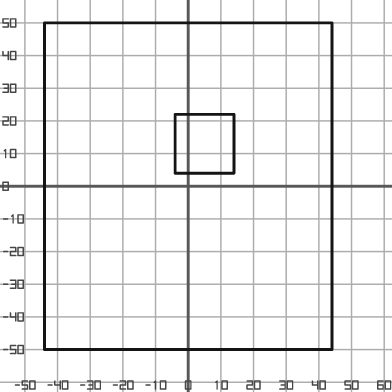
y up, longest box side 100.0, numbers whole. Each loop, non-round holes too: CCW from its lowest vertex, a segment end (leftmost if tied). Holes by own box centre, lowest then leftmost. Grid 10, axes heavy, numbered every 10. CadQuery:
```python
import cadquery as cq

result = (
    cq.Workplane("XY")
    .moveTo(-44.0, -50.0)
    .lineTo(44.0, -50.0)
    .lineTo(44.0, 50.0)
    .lineTo(-44.0, 50.0)
    .close()
    .moveTo(-4.0, 4.0)
    .lineTo(14.0, 4.0)
    .lineTo(14.0, 22.0)
    .lineTo(-4.0, 22.0)
    .close()
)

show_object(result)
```